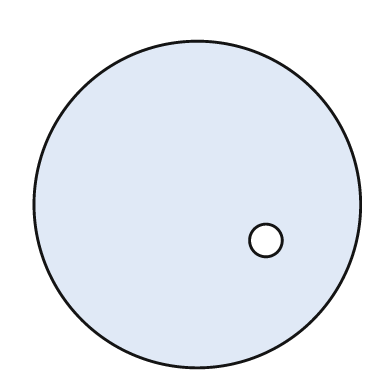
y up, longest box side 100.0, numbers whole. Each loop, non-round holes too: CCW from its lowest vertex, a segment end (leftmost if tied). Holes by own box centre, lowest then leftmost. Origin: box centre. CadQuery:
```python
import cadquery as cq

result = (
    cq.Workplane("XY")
    .moveTo(0.0, 0.0)
    .circle(50.0)
    .moveTo(21.0, -11.0)
    .circle(5.0)
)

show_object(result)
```